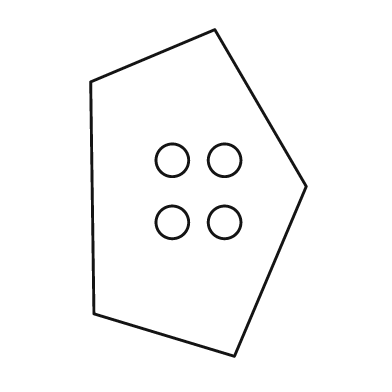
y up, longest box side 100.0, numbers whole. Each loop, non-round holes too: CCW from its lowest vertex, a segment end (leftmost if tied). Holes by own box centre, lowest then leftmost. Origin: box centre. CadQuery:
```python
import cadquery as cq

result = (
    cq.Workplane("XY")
    .moveTo(11.0, -50.0)
    .lineTo(33.0, 2.0)
    .lineTo(5.0, 50.0)
    .lineTo(-33.0, 34.0)
    .lineTo(-32.0, -37.0)
    .close()
    .moveTo(-8.0, -9.0)
    .circle(5.0)
    .moveTo(8.0, -9.0)
    .circle(5.0)
    .moveTo(-8.0, 10.0)
    .circle(5.0)
    .moveTo(8.0, 10.0)
    .circle(5.0)
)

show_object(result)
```